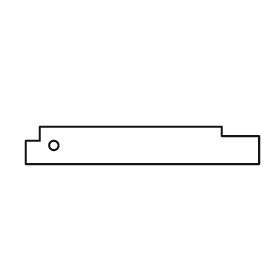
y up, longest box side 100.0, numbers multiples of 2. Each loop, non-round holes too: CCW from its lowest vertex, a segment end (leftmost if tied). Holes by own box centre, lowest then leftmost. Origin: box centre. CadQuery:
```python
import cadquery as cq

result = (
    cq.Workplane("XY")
    .moveTo(-50.0, -8.0)
    .lineTo(50.0, -8.0)
    .lineTo(50.0, 4.0)
    .lineTo(34.0, 4.0)
    .lineTo(34.0, 8.0)
    .lineTo(-44.0, 8.0)
    .lineTo(-44.0, 2.0)
    .lineTo(-50.0, 2.0)
    .close()
    .moveTo(-38.0, 0.0)
    .circle(2.0)
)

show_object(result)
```